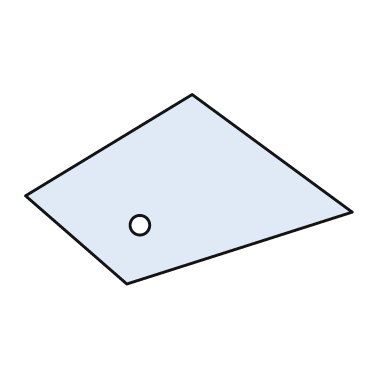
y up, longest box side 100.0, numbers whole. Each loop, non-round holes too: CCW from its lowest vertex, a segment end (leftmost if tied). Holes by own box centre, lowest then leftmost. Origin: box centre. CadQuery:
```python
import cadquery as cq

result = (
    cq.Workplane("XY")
    .moveTo(-19.0, -29.0)
    .lineTo(50.0, -7.0)
    .lineTo(1.0, 29.0)
    .lineTo(-50.0, -2.0)
    .close()
    .moveTo(-15.0, -11.0)
    .circle(3.0)
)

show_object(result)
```